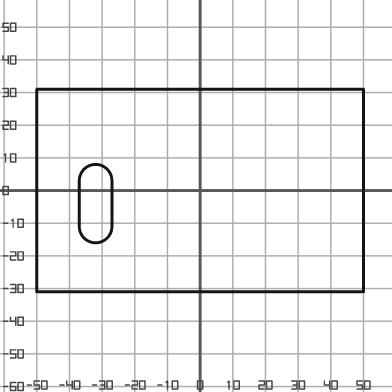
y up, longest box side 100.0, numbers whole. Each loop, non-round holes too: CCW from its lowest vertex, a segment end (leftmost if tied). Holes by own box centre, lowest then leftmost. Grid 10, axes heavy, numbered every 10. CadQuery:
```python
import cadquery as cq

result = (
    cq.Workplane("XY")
    .moveTo(-50.0, -31.0)
    .lineTo(50.0, -31.0)
    .lineTo(50.0, 31.0)
    .lineTo(-50.0, 31.0)
    .close()
    .moveTo(-37.0, -11.0)
    .threePointArc((-32.0, -16.0), (-27.0, -11.0))
    .lineTo(-27.0, 3.0)
    .threePointArc((-32.0, 8.0), (-37.0, 3.0))
    .close()
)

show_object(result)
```